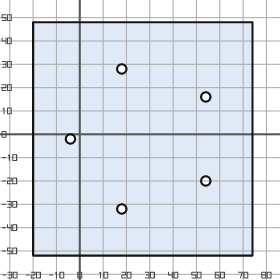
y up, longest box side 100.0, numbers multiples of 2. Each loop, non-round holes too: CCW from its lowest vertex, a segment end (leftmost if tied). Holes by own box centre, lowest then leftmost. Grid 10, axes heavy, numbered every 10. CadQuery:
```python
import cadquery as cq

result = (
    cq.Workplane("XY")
    .moveTo(-20.0, -52.0)
    .lineTo(74.0, -52.0)
    .lineTo(74.0, 48.0)
    .lineTo(-20.0, 48.0)
    .close()
    .moveTo(18.0, -32.0)
    .circle(2.0)
    .moveTo(54.0, -20.0)
    .circle(2.0)
    .moveTo(-4.0, -2.0)
    .circle(2.0)
    .moveTo(54.0, 16.0)
    .circle(2.0)
    .moveTo(18.0, 28.0)
    .circle(2.0)
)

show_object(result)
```